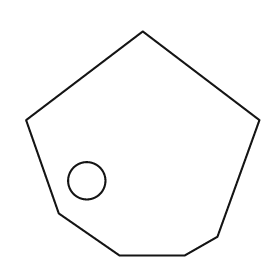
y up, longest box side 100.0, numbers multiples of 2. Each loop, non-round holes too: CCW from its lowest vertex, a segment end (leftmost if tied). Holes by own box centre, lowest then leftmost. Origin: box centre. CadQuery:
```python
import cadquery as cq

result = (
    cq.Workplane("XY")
    .moveTo(-10.0, -48.0)
    .lineTo(18.0, -48.0)
    .lineTo(32.0, -40.0)
    .lineTo(50.0, 10.0)
    .lineTo(0.0, 48.0)
    .lineTo(-50.0, 10.0)
    .lineTo(-36.0, -30.0)
    .close()
    .moveTo(-24.0, -16.0)
    .circle(8.0)
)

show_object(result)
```